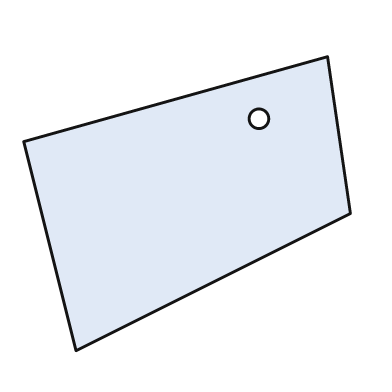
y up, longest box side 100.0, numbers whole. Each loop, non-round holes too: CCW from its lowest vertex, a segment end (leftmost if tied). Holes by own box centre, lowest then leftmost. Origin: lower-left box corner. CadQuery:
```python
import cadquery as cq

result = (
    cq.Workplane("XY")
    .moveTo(16.0, 0.0)
    .lineTo(100.0, 42.0)
    .lineTo(93.0, 90.0)
    .lineTo(0.0, 64.0)
    .close()
    .moveTo(72.0, 71.0)
    .circle(3.0)
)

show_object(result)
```